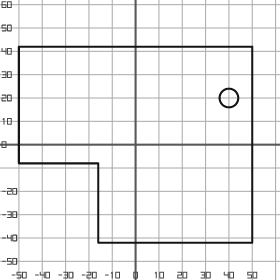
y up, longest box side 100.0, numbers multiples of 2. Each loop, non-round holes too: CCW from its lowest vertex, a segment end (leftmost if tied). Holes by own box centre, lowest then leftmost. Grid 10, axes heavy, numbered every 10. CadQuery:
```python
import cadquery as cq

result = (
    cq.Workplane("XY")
    .moveTo(-16.0, -42.0)
    .lineTo(50.0, -42.0)
    .lineTo(50.0, 42.0)
    .lineTo(-50.0, 42.0)
    .lineTo(-50.0, -8.0)
    .lineTo(-16.0, -8.0)
    .close()
    .moveTo(40.0, 20.0)
    .circle(4.0)
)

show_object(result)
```